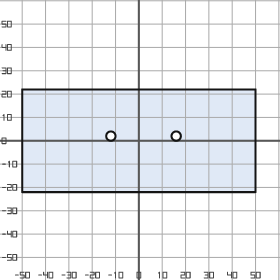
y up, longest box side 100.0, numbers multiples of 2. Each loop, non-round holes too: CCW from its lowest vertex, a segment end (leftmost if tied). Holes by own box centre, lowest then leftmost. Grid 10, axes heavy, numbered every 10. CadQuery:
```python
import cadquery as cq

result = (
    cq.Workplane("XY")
    .moveTo(-50.0, -22.0)
    .lineTo(50.0, -22.0)
    .lineTo(50.0, 22.0)
    .lineTo(-50.0, 22.0)
    .close()
    .moveTo(-12.0, 2.0)
    .circle(2.0)
    .moveTo(16.0, 2.0)
    .circle(2.0)
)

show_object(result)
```